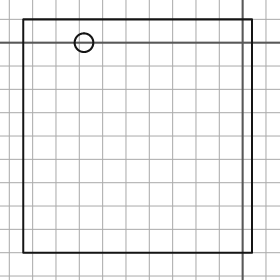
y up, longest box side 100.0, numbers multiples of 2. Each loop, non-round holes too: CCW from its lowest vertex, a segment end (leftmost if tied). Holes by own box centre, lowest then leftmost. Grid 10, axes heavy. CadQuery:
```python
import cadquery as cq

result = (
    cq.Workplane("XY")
    .moveTo(-94.0, -90.0)
    .lineTo(4.0, -90.0)
    .lineTo(4.0, 10.0)
    .lineTo(-94.0, 10.0)
    .close()
    .moveTo(-68.0, 0.0)
    .circle(4.0)
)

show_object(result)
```